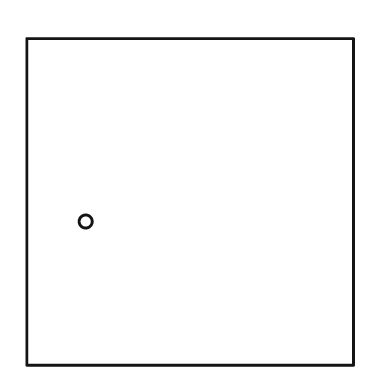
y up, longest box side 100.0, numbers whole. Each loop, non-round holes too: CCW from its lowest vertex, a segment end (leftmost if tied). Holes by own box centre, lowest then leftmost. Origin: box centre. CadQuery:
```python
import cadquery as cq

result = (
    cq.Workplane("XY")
    .moveTo(-50.0, -50.0)
    .lineTo(50.0, -50.0)
    .lineTo(50.0, 50.0)
    .lineTo(-50.0, 50.0)
    .close()
    .moveTo(-32.0, -6.0)
    .circle(2.0)
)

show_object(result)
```